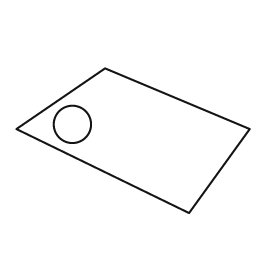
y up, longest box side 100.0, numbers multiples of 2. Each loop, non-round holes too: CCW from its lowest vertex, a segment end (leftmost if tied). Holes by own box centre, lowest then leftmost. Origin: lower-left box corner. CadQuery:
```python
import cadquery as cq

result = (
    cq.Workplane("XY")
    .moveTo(74.0, 0.0)
    .lineTo(100.0, 36.0)
    .lineTo(38.0, 62.0)
    .lineTo(0.0, 36.0)
    .close()
    .moveTo(24.0, 38.0)
    .circle(8.0)
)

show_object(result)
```